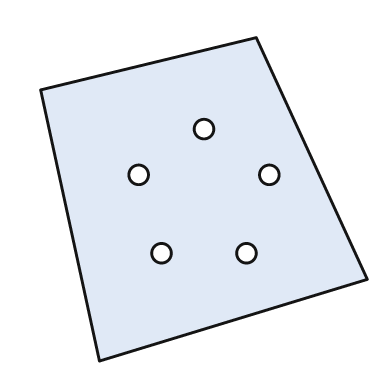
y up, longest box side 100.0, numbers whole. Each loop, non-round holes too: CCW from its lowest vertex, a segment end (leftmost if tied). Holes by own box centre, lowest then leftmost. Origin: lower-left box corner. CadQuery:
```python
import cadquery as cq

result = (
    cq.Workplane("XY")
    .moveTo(18.0, 0.0)
    .lineTo(100.0, 25.0)
    .lineTo(66.0, 99.0)
    .lineTo(0.0, 83.0)
    .close()
    .moveTo(37.0, 33.0)
    .circle(3.0)
    .moveTo(63.0, 33.0)
    .circle(3.0)
    .moveTo(30.0, 57.0)
    .circle(3.0)
    .moveTo(70.0, 57.0)
    .circle(3.0)
    .moveTo(50.0, 71.0)
    .circle(3.0)
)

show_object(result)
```